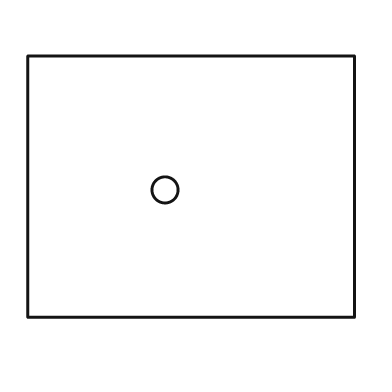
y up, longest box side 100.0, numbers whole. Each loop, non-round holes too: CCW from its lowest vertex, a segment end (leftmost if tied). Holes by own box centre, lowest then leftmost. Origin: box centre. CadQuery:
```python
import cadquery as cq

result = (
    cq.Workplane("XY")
    .moveTo(-50.0, -40.0)
    .lineTo(50.0, -40.0)
    .lineTo(50.0, 40.0)
    .lineTo(-50.0, 40.0)
    .close()
    .moveTo(-8.0, -1.0)
    .circle(4.0)
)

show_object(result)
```